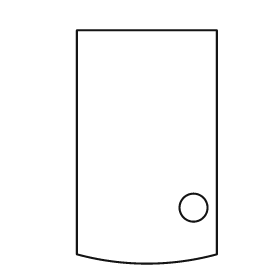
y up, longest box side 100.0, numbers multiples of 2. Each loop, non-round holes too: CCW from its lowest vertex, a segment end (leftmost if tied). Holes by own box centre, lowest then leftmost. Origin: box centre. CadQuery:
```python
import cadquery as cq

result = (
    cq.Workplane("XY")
    .moveTo(-30.0, -46.0)
    .threePointArc((0.0, -50.0), (30.0, -46.0))
    .lineTo(30.0, 50.0)
    .lineTo(-30.0, 50.0)
    .close()
    .moveTo(20.0, -26.0)
    .circle(6.0)
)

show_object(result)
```